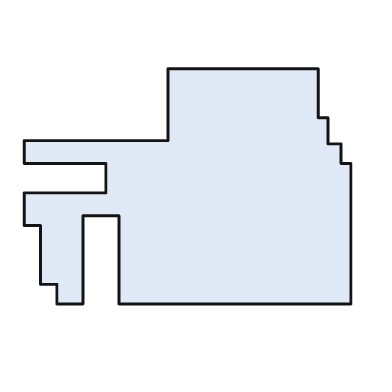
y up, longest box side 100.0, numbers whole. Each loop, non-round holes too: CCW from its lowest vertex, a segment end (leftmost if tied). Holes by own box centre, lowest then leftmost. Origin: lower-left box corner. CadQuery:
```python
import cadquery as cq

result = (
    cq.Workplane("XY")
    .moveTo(10.0, 0.0)
    .lineTo(18.0, 0.0)
    .lineTo(18.0, 27.0)
    .lineTo(29.0, 27.0)
    .lineTo(29.0, 0.0)
    .lineTo(100.0, 0.0)
    .lineTo(100.0, 43.0)
    .lineTo(97.0, 43.0)
    .lineTo(97.0, 49.0)
    .lineTo(93.0, 49.0)
    .lineTo(93.0, 57.0)
    .lineTo(90.0, 57.0)
    .lineTo(90.0, 72.0)
    .lineTo(44.0, 72.0)
    .lineTo(44.0, 50.0)
    .lineTo(0.0, 50.0)
    .lineTo(0.0, 43.0)
    .lineTo(25.0, 43.0)
    .lineTo(25.0, 34.0)
    .lineTo(0.0, 34.0)
    .lineTo(0.0, 24.0)
    .lineTo(5.0, 24.0)
    .lineTo(5.0, 6.0)
    .lineTo(10.0, 6.0)
    .close()
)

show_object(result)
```